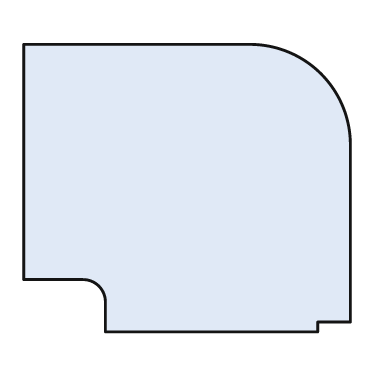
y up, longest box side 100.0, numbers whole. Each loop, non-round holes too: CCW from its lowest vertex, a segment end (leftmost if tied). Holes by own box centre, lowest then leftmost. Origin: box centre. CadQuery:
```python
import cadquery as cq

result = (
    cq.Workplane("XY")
    .moveTo(-25.0, -44.0)
    .lineTo(40.0, -44.0)
    .lineTo(40.0, -41.0)
    .lineTo(50.0, -41.0)
    .lineTo(50.0, 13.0)
    .threePointArc((41.0, 35.0), (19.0, 44.0))
    .lineTo(-50.0, 44.0)
    .lineTo(-50.0, -28.0)
    .lineTo(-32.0, -28.0)
    .threePointArc((-27.0, -30.0), (-25.0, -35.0))
    .close()
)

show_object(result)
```